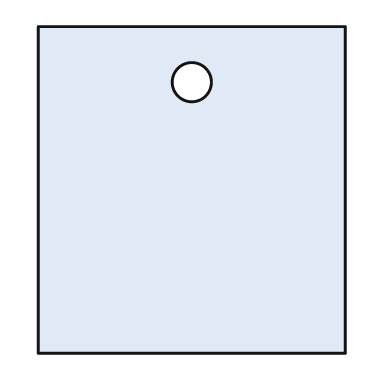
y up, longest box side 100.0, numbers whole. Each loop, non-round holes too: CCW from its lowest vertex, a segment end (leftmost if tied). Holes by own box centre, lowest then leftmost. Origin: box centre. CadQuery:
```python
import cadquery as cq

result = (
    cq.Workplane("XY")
    .moveTo(-47.0, -50.0)
    .lineTo(47.0, -50.0)
    .lineTo(47.0, 50.0)
    .lineTo(-47.0, 50.0)
    .close()
    .moveTo(0.0, 33.0)
    .circle(6.0)
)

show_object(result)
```